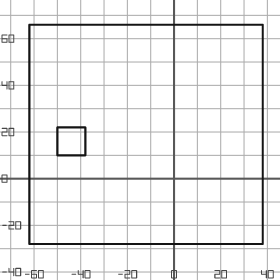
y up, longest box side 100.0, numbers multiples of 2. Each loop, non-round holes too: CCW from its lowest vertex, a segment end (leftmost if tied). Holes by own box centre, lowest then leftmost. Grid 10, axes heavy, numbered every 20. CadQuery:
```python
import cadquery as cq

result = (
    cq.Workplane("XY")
    .moveTo(-62.0, -28.0)
    .lineTo(38.0, -28.0)
    .lineTo(38.0, 66.0)
    .lineTo(-62.0, 66.0)
    .close()
    .moveTo(-50.0, 10.0)
    .lineTo(-38.0, 10.0)
    .lineTo(-38.0, 22.0)
    .lineTo(-50.0, 22.0)
    .close()
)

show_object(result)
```